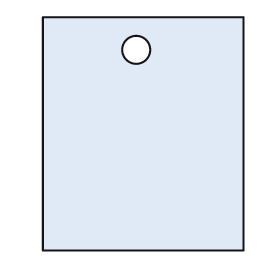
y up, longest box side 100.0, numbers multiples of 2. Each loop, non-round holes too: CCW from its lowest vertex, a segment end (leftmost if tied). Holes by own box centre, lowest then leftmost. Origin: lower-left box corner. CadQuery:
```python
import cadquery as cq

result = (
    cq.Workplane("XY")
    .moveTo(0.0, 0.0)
    .lineTo(86.0, 0.0)
    .lineTo(86.0, 100.0)
    .lineTo(0.0, 100.0)
    .close()
    .moveTo(40.0, 86.0)
    .circle(6.0)
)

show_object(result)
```